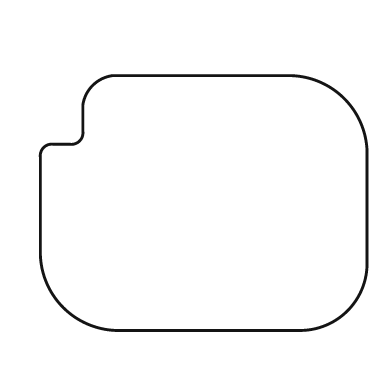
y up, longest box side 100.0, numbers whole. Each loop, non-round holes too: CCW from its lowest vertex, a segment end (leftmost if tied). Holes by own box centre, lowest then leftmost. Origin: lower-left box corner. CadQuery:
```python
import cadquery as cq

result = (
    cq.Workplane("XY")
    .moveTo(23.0, 0.0)
    .lineTo(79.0, 0.0)
    .threePointArc((94.0, 6.0), (100.0, 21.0))
    .lineTo(100.0, 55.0)
    .threePointArc((93.0, 71.0), (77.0, 78.0))
    .lineTo(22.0, 78.0)
    .threePointArc((16.0, 75.0), (13.0, 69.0))
    .lineTo(13.0, 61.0)
    .threePointArc((12.0, 58.0), (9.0, 57.0))
    .lineTo(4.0, 57.0)
    .threePointArc((1.0, 56.0), (0.0, 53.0))
    .lineTo(0.0, 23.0)
    .threePointArc((7.0, 7.0), (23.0, 0.0))
    .close()
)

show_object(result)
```